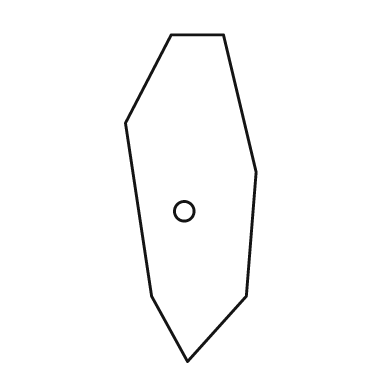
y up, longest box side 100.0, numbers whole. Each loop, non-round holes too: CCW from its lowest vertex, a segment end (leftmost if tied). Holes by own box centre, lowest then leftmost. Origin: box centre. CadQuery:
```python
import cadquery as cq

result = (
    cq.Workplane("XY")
    .moveTo(-1.0, -50.0)
    .lineTo(17.0, -30.0)
    .lineTo(20.0, 8.0)
    .lineTo(10.0, 50.0)
    .lineTo(-6.0, 50.0)
    .lineTo(-20.0, 23.0)
    .lineTo(-12.0, -30.0)
    .close()
    .moveTo(-2.0, -4.0)
    .circle(3.0)
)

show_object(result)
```